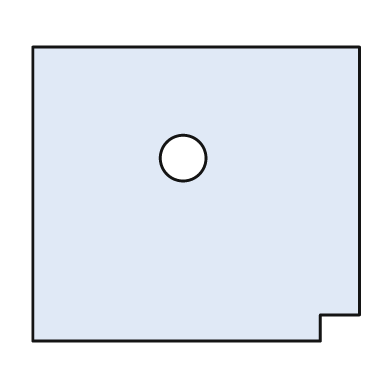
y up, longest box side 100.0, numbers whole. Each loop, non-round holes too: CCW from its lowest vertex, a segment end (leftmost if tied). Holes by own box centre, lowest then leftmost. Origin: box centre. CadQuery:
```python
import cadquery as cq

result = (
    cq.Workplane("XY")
    .moveTo(-50.0, -45.0)
    .lineTo(38.0, -45.0)
    .lineTo(38.0, -37.0)
    .lineTo(50.0, -37.0)
    .lineTo(50.0, 45.0)
    .lineTo(-50.0, 45.0)
    .close()
    .moveTo(-4.0, 11.0)
    .circle(7.0)
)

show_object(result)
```